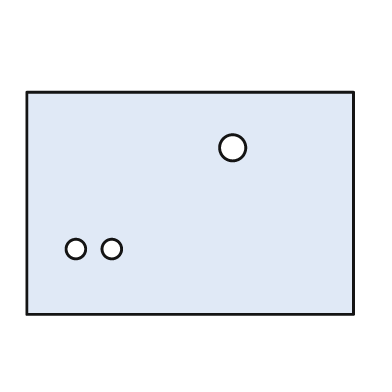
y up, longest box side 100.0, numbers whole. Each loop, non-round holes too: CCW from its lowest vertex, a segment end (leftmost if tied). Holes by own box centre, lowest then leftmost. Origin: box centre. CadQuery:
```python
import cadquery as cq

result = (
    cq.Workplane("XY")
    .moveTo(-50.0, -34.0)
    .lineTo(50.0, -34.0)
    .lineTo(50.0, 34.0)
    .lineTo(-50.0, 34.0)
    .close()
    .moveTo(-35.0, -14.0)
    .circle(3.0)
    .moveTo(-24.0, -14.0)
    .circle(3.0)
    .moveTo(13.0, 17.0)
    .circle(4.0)
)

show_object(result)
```